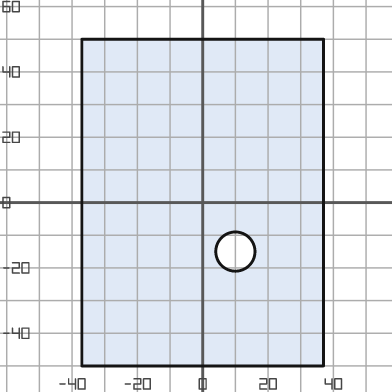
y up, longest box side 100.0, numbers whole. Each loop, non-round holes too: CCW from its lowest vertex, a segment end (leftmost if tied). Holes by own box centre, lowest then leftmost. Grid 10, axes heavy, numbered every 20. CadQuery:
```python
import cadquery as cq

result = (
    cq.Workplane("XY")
    .moveTo(-37.0, -50.0)
    .lineTo(37.0, -50.0)
    .lineTo(37.0, 50.0)
    .lineTo(-37.0, 50.0)
    .close()
    .moveTo(10.0, -15.0)
    .circle(6.0)
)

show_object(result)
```